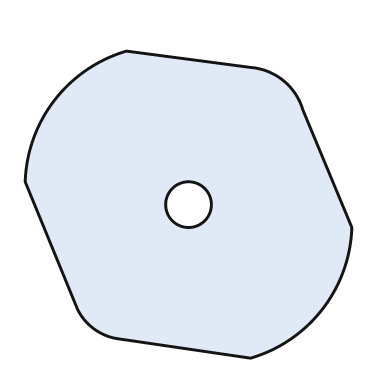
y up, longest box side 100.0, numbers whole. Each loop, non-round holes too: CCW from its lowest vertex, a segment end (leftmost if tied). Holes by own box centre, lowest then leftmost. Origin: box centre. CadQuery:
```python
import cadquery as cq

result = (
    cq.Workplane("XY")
    .moveTo(19.0, -47.0)
    .threePointArc((41.0, -32.0), (50.0, -7.0))
    .lineTo(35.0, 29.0)
    .threePointArc((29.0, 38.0), (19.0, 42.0))
    .lineTo(-19.0, 47.0)
    .threePointArc((-41.0, 32.0), (-50.0, 7.0))
    .lineTo(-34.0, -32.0)
    .threePointArc((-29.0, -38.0), (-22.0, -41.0))
    .close()
    .moveTo(0.0, 0.0)
    .circle(7.0)
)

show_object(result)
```